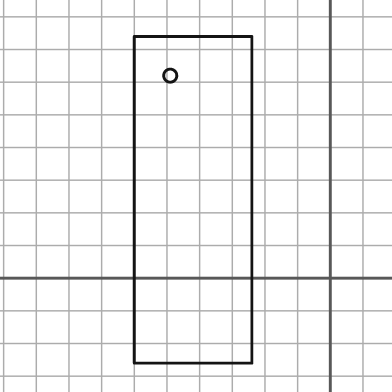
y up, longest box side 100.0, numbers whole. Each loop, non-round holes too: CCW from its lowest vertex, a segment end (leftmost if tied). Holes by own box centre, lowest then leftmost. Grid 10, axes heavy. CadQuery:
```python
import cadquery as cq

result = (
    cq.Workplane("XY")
    .moveTo(-60.0, -26.0)
    .lineTo(-24.0, -26.0)
    .lineTo(-24.0, 74.0)
    .lineTo(-60.0, 74.0)
    .close()
    .moveTo(-49.0, 62.0)
    .circle(2.0)
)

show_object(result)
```